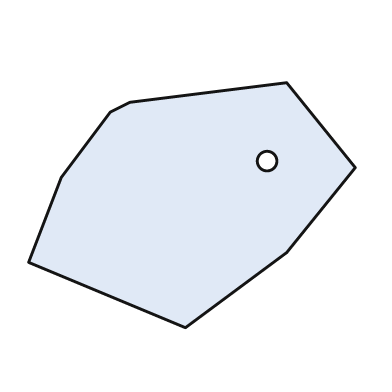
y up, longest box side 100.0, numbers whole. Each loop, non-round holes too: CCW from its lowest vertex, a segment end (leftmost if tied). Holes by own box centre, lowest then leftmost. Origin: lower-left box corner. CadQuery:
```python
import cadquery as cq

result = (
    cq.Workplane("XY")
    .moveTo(48.0, 0.0)
    .lineTo(79.0, 23.0)
    .lineTo(100.0, 49.0)
    .lineTo(79.0, 75.0)
    .lineTo(31.0, 69.0)
    .lineTo(25.0, 66.0)
    .lineTo(10.0, 46.0)
    .lineTo(0.0, 20.0)
    .close()
    .moveTo(73.0, 51.0)
    .circle(3.0)
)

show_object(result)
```